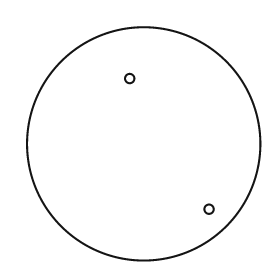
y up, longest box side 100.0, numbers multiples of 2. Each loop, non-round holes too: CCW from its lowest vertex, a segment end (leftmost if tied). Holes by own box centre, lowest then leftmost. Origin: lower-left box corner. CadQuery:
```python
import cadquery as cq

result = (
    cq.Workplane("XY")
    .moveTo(50.0, 50.0)
    .circle(50.0)
    .moveTo(78.0, 22.0)
    .circle(2.0)
    .moveTo(44.0, 78.0)
    .circle(2.0)
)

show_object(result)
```